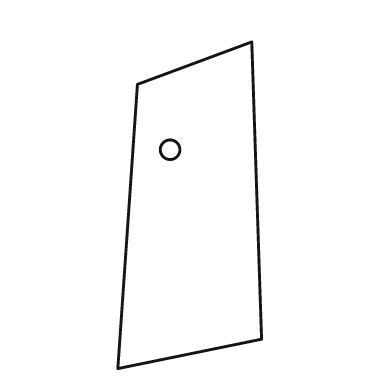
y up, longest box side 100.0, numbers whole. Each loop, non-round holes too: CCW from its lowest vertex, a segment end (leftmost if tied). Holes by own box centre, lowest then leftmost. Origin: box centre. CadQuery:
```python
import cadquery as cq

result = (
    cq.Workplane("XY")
    .moveTo(-22.0, -50.0)
    .lineTo(22.0, -41.0)
    .lineTo(19.0, 50.0)
    .lineTo(-16.0, 37.0)
    .close()
    .moveTo(-6.0, 17.0)
    .circle(3.0)
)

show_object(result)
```